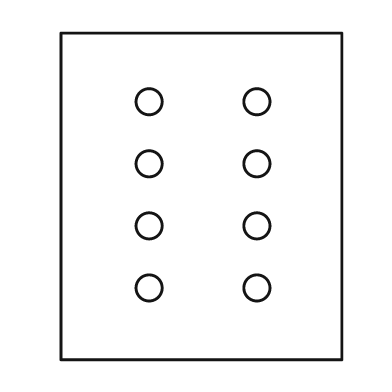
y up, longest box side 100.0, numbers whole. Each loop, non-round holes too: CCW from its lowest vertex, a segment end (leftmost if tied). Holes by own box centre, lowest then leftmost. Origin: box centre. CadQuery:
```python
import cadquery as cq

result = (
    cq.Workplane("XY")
    .moveTo(-43.0, -50.0)
    .lineTo(43.0, -50.0)
    .lineTo(43.0, 50.0)
    .lineTo(-43.0, 50.0)
    .close()
    .moveTo(-16.0, -28.0)
    .circle(4.0)
    .moveTo(17.0, -28.0)
    .circle(4.0)
    .moveTo(-16.0, -9.0)
    .circle(4.0)
    .moveTo(17.0, -9.0)
    .circle(4.0)
    .moveTo(-16.0, 10.0)
    .circle(4.0)
    .moveTo(17.0, 10.0)
    .circle(4.0)
    .moveTo(-16.0, 29.0)
    .circle(4.0)
    .moveTo(17.0, 29.0)
    .circle(4.0)
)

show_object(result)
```